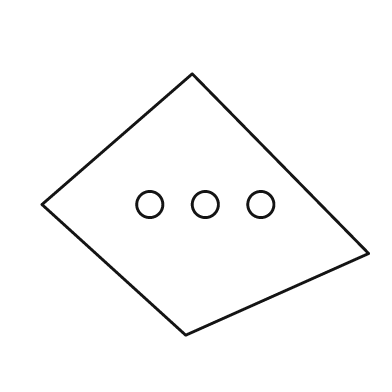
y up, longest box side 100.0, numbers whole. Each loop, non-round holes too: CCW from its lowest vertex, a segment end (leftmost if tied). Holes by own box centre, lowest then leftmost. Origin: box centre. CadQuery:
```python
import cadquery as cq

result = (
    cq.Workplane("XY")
    .moveTo(-6.0, -40.0)
    .lineTo(50.0, -15.0)
    .lineTo(-4.0, 40.0)
    .lineTo(-50.0, 0.0)
    .close()
    .moveTo(-17.0, 0.0)
    .circle(4.0)
    .moveTo(0.0, 0.0)
    .circle(4.0)
    .moveTo(17.0, 0.0)
    .circle(4.0)
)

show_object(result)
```